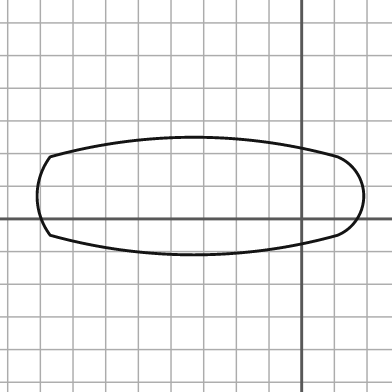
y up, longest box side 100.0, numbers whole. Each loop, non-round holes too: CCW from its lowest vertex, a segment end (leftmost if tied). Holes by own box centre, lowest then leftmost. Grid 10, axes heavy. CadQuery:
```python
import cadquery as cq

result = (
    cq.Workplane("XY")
    .moveTo(-77.0, -5.0)
    .threePointArc((-33.0, -11.0), (11.0, -5.0))
    .threePointArc((19.0, 7.0), (11.0, 19.0))
    .threePointArc((-33.0, 25.0), (-77.0, 19.0))
    .threePointArc((-81.0, 7.0), (-77.0, -5.0))
    .close()
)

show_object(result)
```